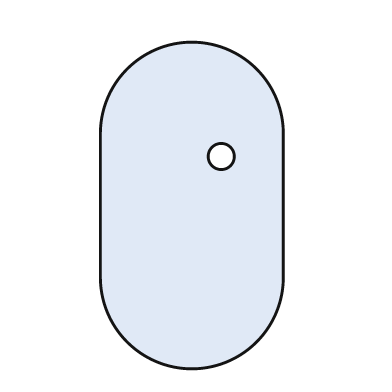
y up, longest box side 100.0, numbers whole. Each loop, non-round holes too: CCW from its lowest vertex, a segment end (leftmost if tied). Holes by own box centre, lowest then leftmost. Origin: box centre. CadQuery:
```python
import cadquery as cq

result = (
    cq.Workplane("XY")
    .moveTo(-28.0, -22.0)
    .threePointArc((0.0, -50.0), (28.0, -22.0))
    .lineTo(28.0, 22.0)
    .threePointArc((0.0, 50.0), (-28.0, 22.0))
    .close()
    .moveTo(9.0, 15.0)
    .circle(4.0)
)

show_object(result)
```